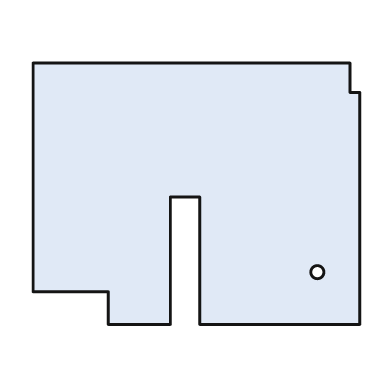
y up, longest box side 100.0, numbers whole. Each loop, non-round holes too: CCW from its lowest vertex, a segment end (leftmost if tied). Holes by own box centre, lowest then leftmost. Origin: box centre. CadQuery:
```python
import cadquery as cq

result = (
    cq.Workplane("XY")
    .moveTo(-27.0, -40.0)
    .lineTo(-8.0, -40.0)
    .lineTo(-8.0, -1.0)
    .lineTo(1.0, -1.0)
    .lineTo(1.0, -40.0)
    .lineTo(50.0, -40.0)
    .lineTo(50.0, 31.0)
    .lineTo(47.0, 31.0)
    .lineTo(47.0, 40.0)
    .lineTo(-50.0, 40.0)
    .lineTo(-50.0, -30.0)
    .lineTo(-27.0, -30.0)
    .close()
    .moveTo(37.0, -24.0)
    .circle(2.0)
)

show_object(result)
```